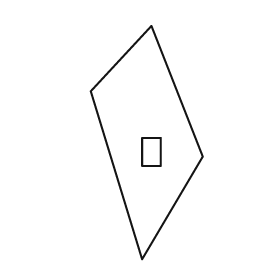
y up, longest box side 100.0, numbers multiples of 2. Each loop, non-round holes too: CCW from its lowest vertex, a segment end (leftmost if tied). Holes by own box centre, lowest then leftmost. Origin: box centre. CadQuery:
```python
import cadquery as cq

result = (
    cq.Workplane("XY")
    .moveTo(-2.0, -50.0)
    .lineTo(24.0, -6.0)
    .lineTo(2.0, 50.0)
    .lineTo(-24.0, 22.0)
    .close()
    .moveTo(-2.0, -10.0)
    .lineTo(6.0, -10.0)
    .lineTo(6.0, 2.0)
    .lineTo(-2.0, 2.0)
    .close()
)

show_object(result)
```